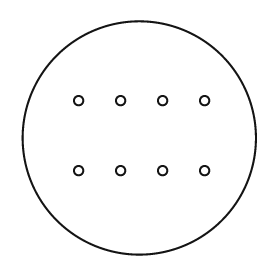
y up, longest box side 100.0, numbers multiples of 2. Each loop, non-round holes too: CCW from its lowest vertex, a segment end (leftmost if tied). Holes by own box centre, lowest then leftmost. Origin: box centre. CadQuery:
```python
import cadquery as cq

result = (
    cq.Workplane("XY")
    .moveTo(0.0, 0.0)
    .circle(50.0)
    .moveTo(-26.0, -14.0)
    .circle(2.0)
    .moveTo(-8.0, -14.0)
    .circle(2.0)
    .moveTo(10.0, -14.0)
    .circle(2.0)
    .moveTo(28.0, -14.0)
    .circle(2.0)
    .moveTo(-26.0, 16.0)
    .circle(2.0)
    .moveTo(-8.0, 16.0)
    .circle(2.0)
    .moveTo(10.0, 16.0)
    .circle(2.0)
    .moveTo(28.0, 16.0)
    .circle(2.0)
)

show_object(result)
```